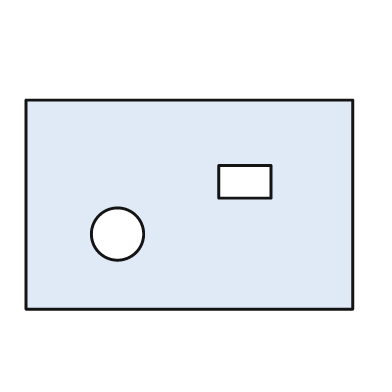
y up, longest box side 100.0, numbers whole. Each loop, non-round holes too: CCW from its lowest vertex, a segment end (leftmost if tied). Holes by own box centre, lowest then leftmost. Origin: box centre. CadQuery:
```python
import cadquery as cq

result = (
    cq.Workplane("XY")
    .moveTo(-50.0, -32.0)
    .lineTo(50.0, -32.0)
    .lineTo(50.0, 32.0)
    .lineTo(-50.0, 32.0)
    .close()
    .moveTo(-22.0, -9.0)
    .circle(8.0)
    .moveTo(9.0, 2.0)
    .lineTo(25.0, 2.0)
    .lineTo(25.0, 12.0)
    .lineTo(9.0, 12.0)
    .close()
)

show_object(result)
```